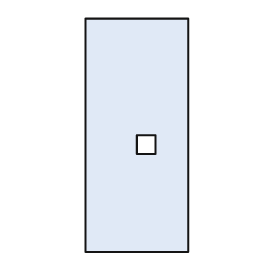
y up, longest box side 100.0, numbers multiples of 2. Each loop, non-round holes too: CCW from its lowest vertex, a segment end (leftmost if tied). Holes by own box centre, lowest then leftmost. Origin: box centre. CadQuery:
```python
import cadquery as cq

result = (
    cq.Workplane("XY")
    .moveTo(-22.0, -50.0)
    .lineTo(22.0, -50.0)
    .lineTo(22.0, 50.0)
    .lineTo(-22.0, 50.0)
    .close()
    .moveTo(0.0, -8.0)
    .lineTo(8.0, -8.0)
    .lineTo(8.0, 0.0)
    .lineTo(0.0, 0.0)
    .close()
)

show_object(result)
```